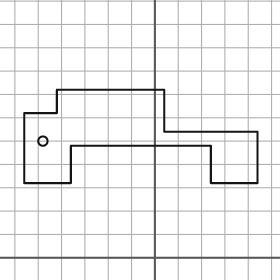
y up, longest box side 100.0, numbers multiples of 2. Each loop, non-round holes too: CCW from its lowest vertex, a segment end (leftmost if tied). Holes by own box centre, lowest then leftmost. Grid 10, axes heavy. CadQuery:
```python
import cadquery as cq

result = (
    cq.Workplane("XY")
    .moveTo(-56.0, 32.0)
    .lineTo(-36.0, 32.0)
    .lineTo(-36.0, 48.0)
    .lineTo(24.0, 48.0)
    .lineTo(24.0, 32.0)
    .lineTo(44.0, 32.0)
    .lineTo(44.0, 54.0)
    .lineTo(4.0, 54.0)
    .lineTo(4.0, 72.0)
    .lineTo(-42.0, 72.0)
    .lineTo(-42.0, 62.0)
    .lineTo(-56.0, 62.0)
    .close()
    .moveTo(-48.0, 50.0)
    .circle(2.0)
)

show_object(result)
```